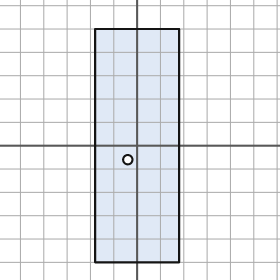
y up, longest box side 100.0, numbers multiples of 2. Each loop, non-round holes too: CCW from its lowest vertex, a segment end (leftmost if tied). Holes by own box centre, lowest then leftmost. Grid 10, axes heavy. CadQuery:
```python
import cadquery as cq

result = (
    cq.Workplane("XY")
    .moveTo(-18.0, -50.0)
    .lineTo(18.0, -50.0)
    .lineTo(18.0, 50.0)
    .lineTo(-18.0, 50.0)
    .close()
    .moveTo(-4.0, -6.0)
    .circle(2.0)
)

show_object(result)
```